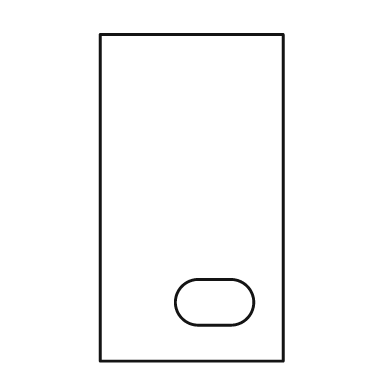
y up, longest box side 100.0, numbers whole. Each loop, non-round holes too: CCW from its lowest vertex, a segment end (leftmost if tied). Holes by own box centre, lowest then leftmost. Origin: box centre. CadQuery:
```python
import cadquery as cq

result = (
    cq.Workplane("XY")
    .moveTo(-28.0, -50.0)
    .lineTo(28.0, -50.0)
    .lineTo(28.0, 50.0)
    .lineTo(-28.0, 50.0)
    .close()
    .moveTo(2.0, -39.0)
    .lineTo(12.0, -39.0)
    .threePointArc((19.0, -32.0), (12.0, -25.0))
    .lineTo(2.0, -25.0)
    .threePointArc((-5.0, -32.0), (2.0, -39.0))
    .close()
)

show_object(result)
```